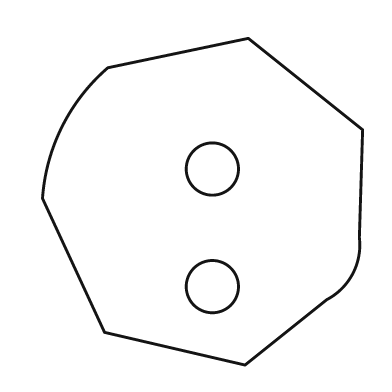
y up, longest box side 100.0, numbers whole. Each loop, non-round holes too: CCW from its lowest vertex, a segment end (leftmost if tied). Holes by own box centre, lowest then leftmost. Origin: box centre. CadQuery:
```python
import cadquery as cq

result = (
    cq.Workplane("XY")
    .moveTo(13.0, -50.0)
    .lineTo(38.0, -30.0)
    .threePointArc((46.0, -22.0), (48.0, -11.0))
    .lineTo(49.0, 22.0)
    .lineTo(14.0, 50.0)
    .lineTo(-29.0, 41.0)
    .threePointArc((-43.0, 23.0), (-49.0, 1.0))
    .lineTo(-30.0, -40.0)
    .close()
    .moveTo(3.0, -26.0)
    .circle(8.0)
    .moveTo(3.0, 10.0)
    .circle(8.0)
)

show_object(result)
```